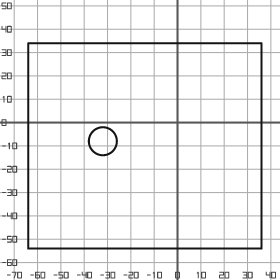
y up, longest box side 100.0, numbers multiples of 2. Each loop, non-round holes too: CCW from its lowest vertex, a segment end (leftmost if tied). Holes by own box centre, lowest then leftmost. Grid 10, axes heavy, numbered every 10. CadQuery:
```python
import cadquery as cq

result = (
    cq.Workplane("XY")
    .moveTo(-64.0, -54.0)
    .lineTo(36.0, -54.0)
    .lineTo(36.0, 34.0)
    .lineTo(-64.0, 34.0)
    .close()
    .moveTo(-32.0, -8.0)
    .circle(6.0)
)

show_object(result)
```